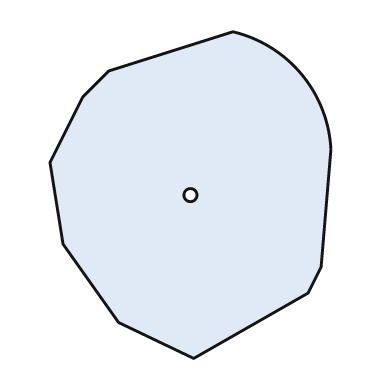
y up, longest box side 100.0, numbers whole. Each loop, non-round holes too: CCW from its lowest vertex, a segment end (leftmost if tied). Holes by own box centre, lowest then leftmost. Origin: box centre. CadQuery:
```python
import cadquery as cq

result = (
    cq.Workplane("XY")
    .moveTo(1.0, -50.0)
    .lineTo(36.0, -30.0)
    .lineTo(40.0, -22.0)
    .lineTo(43.0, 14.0)
    .threePointArc((34.0, 37.0), (13.0, 50.0))
    .lineTo(-25.0, 38.0)
    .lineTo(-33.0, 30.0)
    .lineTo(-43.0, 10.0)
    .lineTo(-39.0, -15.0)
    .lineTo(-22.0, -39.0)
    .close()
    .moveTo(0.0, 0.0)
    .circle(2.0)
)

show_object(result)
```